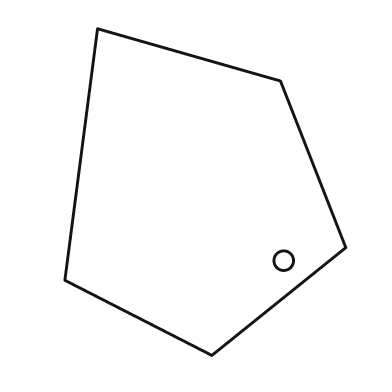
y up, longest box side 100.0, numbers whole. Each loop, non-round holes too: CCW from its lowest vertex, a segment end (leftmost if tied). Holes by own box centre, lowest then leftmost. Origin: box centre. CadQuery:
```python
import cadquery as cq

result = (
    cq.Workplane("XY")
    .moveTo(2.0, -50.0)
    .lineTo(43.0, -17.0)
    .lineTo(23.0, 34.0)
    .lineTo(-33.0, 50.0)
    .lineTo(-43.0, -27.0)
    .close()
    .moveTo(24.0, -21.0)
    .circle(3.0)
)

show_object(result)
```